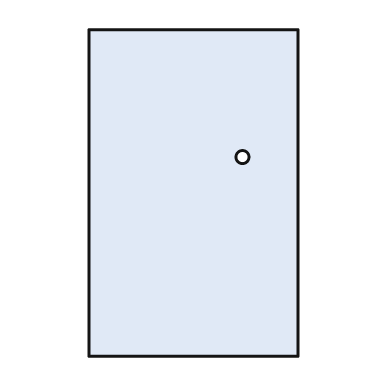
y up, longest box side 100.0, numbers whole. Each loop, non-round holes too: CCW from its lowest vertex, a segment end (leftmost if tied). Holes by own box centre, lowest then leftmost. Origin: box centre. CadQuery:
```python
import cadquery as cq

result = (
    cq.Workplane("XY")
    .moveTo(-32.0, -50.0)
    .lineTo(32.0, -50.0)
    .lineTo(32.0, 50.0)
    .lineTo(-32.0, 50.0)
    .close()
    .moveTo(15.0, 11.0)
    .circle(2.0)
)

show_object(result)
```